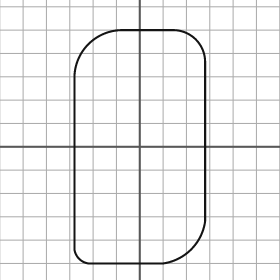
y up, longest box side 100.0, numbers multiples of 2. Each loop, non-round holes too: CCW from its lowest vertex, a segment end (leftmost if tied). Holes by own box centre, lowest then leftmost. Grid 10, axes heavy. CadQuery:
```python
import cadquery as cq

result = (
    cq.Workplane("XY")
    .moveTo(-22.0, -50.0)
    .lineTo(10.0, -50.0)
    .threePointArc((22.0, -44.0), (28.0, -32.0))
    .lineTo(28.0, 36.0)
    .threePointArc((24.0, 46.0), (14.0, 50.0))
    .lineTo(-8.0, 50.0)
    .threePointArc((-22.0, 44.0), (-28.0, 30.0))
    .lineTo(-28.0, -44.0)
    .threePointArc((-26.0, -48.0), (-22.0, -50.0))
    .close()
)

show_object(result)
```